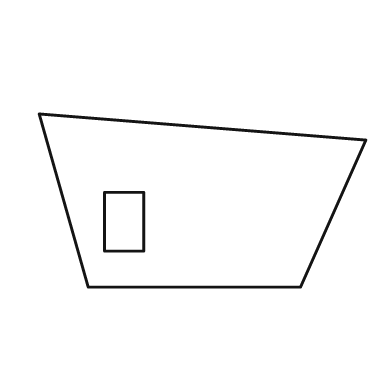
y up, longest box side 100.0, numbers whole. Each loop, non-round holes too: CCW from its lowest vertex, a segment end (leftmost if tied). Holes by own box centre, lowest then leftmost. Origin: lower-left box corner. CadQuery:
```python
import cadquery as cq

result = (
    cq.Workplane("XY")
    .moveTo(15.0, 0.0)
    .lineTo(80.0, 0.0)
    .lineTo(100.0, 45.0)
    .lineTo(0.0, 53.0)
    .close()
    .moveTo(20.0, 11.0)
    .lineTo(32.0, 11.0)
    .lineTo(32.0, 29.0)
    .lineTo(20.0, 29.0)
    .close()
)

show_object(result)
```